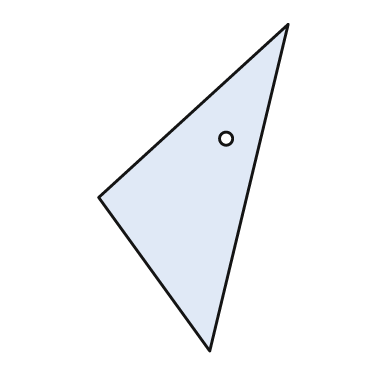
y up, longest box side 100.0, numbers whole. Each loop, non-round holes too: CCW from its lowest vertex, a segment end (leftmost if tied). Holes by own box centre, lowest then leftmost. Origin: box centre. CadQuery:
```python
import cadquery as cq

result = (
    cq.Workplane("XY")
    .moveTo(5.0, -50.0)
    .lineTo(29.0, 50.0)
    .lineTo(-29.0, -3.0)
    .close()
    .moveTo(10.0, 15.0)
    .circle(2.0)
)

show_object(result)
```